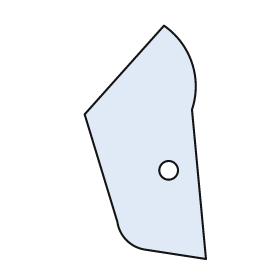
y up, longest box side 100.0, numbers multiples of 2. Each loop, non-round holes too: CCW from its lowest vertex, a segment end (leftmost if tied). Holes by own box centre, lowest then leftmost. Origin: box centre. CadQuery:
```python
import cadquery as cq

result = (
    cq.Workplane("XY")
    .moveTo(26.0, -50.0)
    .lineTo(20.0, 14.0)
    .threePointArc((20.0, 34.0), (8.0, 50.0))
    .lineTo(-26.0, 12.0)
    .lineTo(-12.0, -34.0)
    .threePointArc((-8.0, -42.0), (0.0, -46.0))
    .close()
    .moveTo(10.0, -12.0)
    .circle(4.0)
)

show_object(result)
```